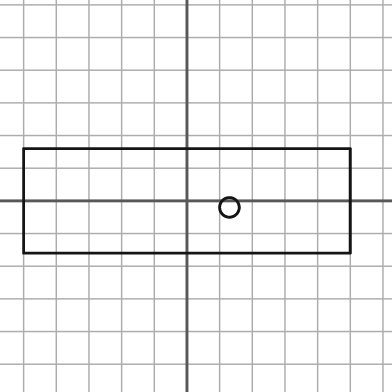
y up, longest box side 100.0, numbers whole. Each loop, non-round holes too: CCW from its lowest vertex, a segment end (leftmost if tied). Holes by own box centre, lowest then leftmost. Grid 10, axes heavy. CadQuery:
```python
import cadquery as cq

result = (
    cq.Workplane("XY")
    .moveTo(-50.0, -16.0)
    .lineTo(50.0, -16.0)
    .lineTo(50.0, 16.0)
    .lineTo(-50.0, 16.0)
    .close()
    .moveTo(13.0, -2.0)
    .circle(3.0)
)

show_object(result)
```